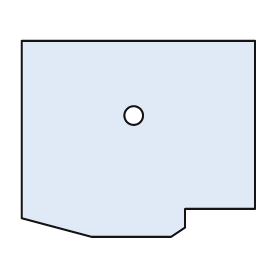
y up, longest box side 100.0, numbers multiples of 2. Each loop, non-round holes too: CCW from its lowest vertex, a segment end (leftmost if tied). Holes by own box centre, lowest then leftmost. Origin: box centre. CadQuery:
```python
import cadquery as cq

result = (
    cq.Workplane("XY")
    .moveTo(-20.0, -42.0)
    .lineTo(14.0, -42.0)
    .lineTo(20.0, -38.0)
    .lineTo(20.0, -30.0)
    .lineTo(50.0, -30.0)
    .lineTo(50.0, 42.0)
    .lineTo(-50.0, 42.0)
    .lineTo(-50.0, -34.0)
    .close()
    .moveTo(-2.0, 10.0)
    .circle(4.0)
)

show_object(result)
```